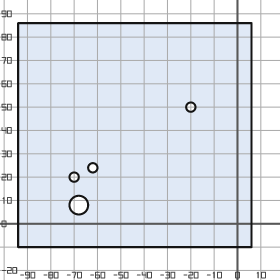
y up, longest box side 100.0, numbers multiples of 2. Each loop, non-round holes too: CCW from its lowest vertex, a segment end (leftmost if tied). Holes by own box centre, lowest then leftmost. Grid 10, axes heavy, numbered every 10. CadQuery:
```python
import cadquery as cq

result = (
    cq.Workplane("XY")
    .moveTo(-94.0, -10.0)
    .lineTo(6.0, -10.0)
    .lineTo(6.0, 86.0)
    .lineTo(-94.0, 86.0)
    .close()
    .moveTo(-68.0, 8.0)
    .circle(4.0)
    .moveTo(-70.0, 20.0)
    .circle(2.0)
    .moveTo(-62.0, 24.0)
    .circle(2.0)
    .moveTo(-20.0, 50.0)
    .circle(2.0)
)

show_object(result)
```